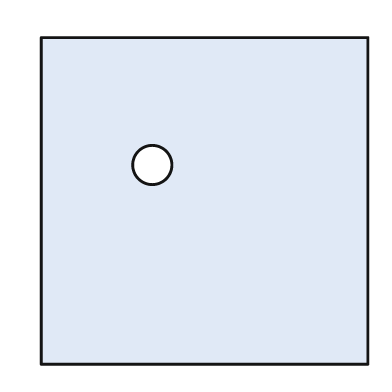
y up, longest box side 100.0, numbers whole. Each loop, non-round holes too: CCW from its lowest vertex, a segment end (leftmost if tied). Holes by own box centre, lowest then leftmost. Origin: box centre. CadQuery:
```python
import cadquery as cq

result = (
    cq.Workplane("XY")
    .moveTo(-50.0, -50.0)
    .lineTo(50.0, -50.0)
    .lineTo(50.0, 50.0)
    .lineTo(-50.0, 50.0)
    .close()
    .moveTo(-16.0, 11.0)
    .circle(6.0)
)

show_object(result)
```